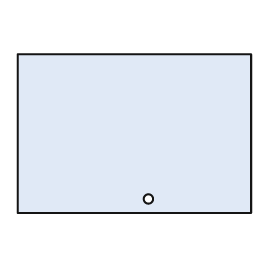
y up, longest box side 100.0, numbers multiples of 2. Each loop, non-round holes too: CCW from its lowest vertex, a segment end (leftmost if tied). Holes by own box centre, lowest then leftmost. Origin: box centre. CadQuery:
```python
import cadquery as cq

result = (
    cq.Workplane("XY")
    .moveTo(-50.0, -34.0)
    .lineTo(50.0, -34.0)
    .lineTo(50.0, 34.0)
    .lineTo(-50.0, 34.0)
    .close()
    .moveTo(6.0, -28.0)
    .circle(2.0)
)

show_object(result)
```